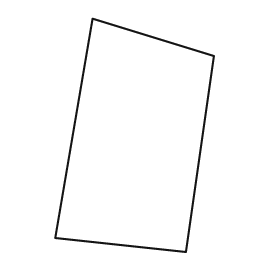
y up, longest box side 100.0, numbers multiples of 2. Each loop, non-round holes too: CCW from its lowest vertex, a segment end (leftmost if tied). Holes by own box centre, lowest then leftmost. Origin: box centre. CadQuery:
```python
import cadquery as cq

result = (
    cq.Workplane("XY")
    .moveTo(22.0, -50.0)
    .lineTo(34.0, 34.0)
    .lineTo(-18.0, 50.0)
    .lineTo(-34.0, -44.0)
    .close()
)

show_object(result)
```